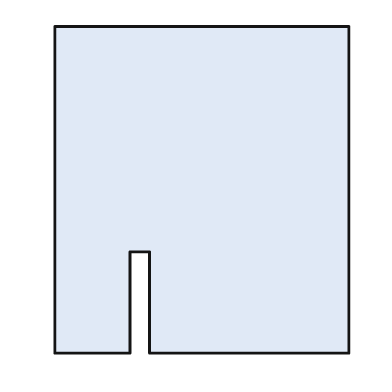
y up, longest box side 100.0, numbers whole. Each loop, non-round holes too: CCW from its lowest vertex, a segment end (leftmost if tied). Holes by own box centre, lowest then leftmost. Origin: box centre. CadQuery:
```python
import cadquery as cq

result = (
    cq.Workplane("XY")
    .moveTo(-45.0, -50.0)
    .lineTo(-22.0, -50.0)
    .lineTo(-22.0, -19.0)
    .lineTo(-16.0, -19.0)
    .lineTo(-16.0, -50.0)
    .lineTo(45.0, -50.0)
    .lineTo(45.0, 50.0)
    .lineTo(-45.0, 50.0)
    .close()
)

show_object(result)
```